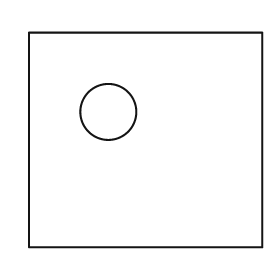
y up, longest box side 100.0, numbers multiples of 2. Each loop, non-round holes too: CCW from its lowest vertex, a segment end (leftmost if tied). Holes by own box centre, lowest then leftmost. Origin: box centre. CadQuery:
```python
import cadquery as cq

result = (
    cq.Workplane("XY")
    .moveTo(-50.0, -46.0)
    .lineTo(50.0, -46.0)
    .lineTo(50.0, 46.0)
    .lineTo(-50.0, 46.0)
    .close()
    .moveTo(-16.0, 12.0)
    .circle(12.0)
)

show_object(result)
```